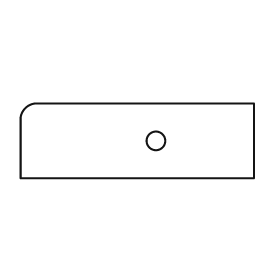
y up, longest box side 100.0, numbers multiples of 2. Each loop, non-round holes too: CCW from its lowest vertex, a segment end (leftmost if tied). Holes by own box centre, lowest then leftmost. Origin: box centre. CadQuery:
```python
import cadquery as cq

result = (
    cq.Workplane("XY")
    .moveTo(-50.0, -16.0)
    .lineTo(50.0, -16.0)
    .lineTo(50.0, 16.0)
    .lineTo(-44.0, 16.0)
    .threePointArc((-48.0, 14.0), (-50.0, 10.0))
    .close()
    .moveTo(8.0, 0.0)
    .circle(4.0)
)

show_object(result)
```